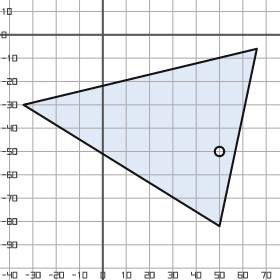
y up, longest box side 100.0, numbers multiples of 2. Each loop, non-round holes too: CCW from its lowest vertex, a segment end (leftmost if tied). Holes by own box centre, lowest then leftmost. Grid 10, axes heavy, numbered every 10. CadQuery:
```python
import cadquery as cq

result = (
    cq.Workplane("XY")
    .moveTo(50.0, -82.0)
    .lineTo(66.0, -6.0)
    .lineTo(-34.0, -30.0)
    .close()
    .moveTo(50.0, -50.0)
    .circle(2.0)
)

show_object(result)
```